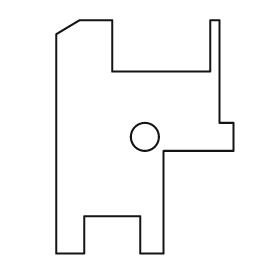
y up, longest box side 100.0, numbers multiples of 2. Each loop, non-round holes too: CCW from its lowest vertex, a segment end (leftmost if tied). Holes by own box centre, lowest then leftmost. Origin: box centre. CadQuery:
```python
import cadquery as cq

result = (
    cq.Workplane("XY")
    .moveTo(-38.0, -50.0)
    .lineTo(-26.0, -50.0)
    .lineTo(-26.0, -34.0)
    .lineTo(-2.0, -34.0)
    .lineTo(-2.0, -50.0)
    .lineTo(8.0, -50.0)
    .lineTo(8.0, -6.0)
    .lineTo(38.0, -6.0)
    .lineTo(38.0, 6.0)
    .lineTo(32.0, 6.0)
    .lineTo(32.0, 50.0)
    .lineTo(28.0, 50.0)
    .lineTo(28.0, 28.0)
    .lineTo(-14.0, 28.0)
    .lineTo(-14.0, 50.0)
    .lineTo(-28.0, 50.0)
    .lineTo(-38.0, 44.0)
    .close()
    .moveTo(0.0, 0.0)
    .circle(6.0)
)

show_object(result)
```